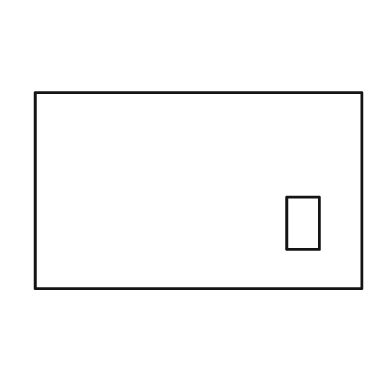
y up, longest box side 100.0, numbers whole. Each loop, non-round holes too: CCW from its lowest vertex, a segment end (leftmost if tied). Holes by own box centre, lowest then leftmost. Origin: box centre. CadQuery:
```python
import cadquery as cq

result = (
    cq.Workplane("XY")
    .moveTo(-50.0, -30.0)
    .lineTo(50.0, -30.0)
    .lineTo(50.0, 30.0)
    .lineTo(-50.0, 30.0)
    .close()
    .moveTo(27.0, -18.0)
    .lineTo(37.0, -18.0)
    .lineTo(37.0, -2.0)
    .lineTo(27.0, -2.0)
    .close()
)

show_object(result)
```